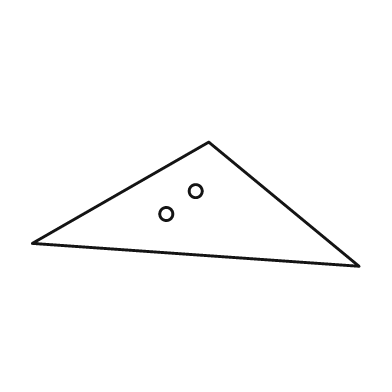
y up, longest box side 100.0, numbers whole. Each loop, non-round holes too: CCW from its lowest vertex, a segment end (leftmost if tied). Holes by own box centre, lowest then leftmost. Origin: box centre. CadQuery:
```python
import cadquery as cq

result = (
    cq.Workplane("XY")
    .moveTo(50.0, -19.0)
    .lineTo(4.0, 19.0)
    .lineTo(-50.0, -12.0)
    .close()
    .moveTo(-9.0, -3.0)
    .circle(2.0)
    .moveTo(0.0, 4.0)
    .circle(2.0)
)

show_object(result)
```